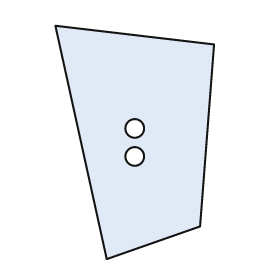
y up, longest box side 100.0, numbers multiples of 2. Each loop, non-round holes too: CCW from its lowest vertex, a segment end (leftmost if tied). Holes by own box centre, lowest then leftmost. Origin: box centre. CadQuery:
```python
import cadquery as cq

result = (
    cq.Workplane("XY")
    .moveTo(-12.0, -50.0)
    .lineTo(28.0, -36.0)
    .lineTo(34.0, 42.0)
    .lineTo(-34.0, 50.0)
    .close()
    .moveTo(0.0, -6.0)
    .circle(4.0)
    .moveTo(0.0, 6.0)
    .circle(4.0)
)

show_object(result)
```